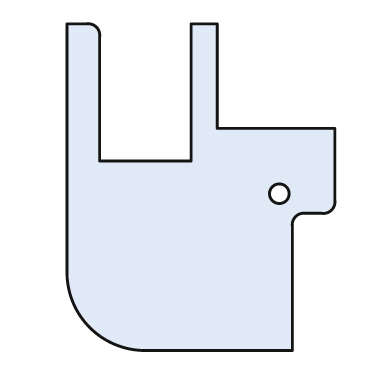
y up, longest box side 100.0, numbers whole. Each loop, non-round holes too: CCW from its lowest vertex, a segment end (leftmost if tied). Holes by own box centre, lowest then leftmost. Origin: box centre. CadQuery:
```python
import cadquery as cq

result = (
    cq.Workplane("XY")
    .moveTo(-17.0, -50.0)
    .lineTo(28.0, -50.0)
    .lineTo(28.0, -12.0)
    .threePointArc((29.0, -9.0), (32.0, -8.0))
    .lineTo(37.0, -8.0)
    .threePointArc((40.0, -7.0), (41.0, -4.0))
    .lineTo(41.0, 18.0)
    .lineTo(5.0, 18.0)
    .lineTo(5.0, 50.0)
    .lineTo(-3.0, 50.0)
    .lineTo(-3.0, 8.0)
    .lineTo(-31.0, 8.0)
    .lineTo(-31.0, 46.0)
    .threePointArc((-32.0, 49.0), (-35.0, 50.0))
    .lineTo(-41.0, 50.0)
    .lineTo(-41.0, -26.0)
    .threePointArc((-34.0, -43.0), (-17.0, -50.0))
    .close()
    .moveTo(24.0, -2.0)
    .circle(3.0)
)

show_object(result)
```